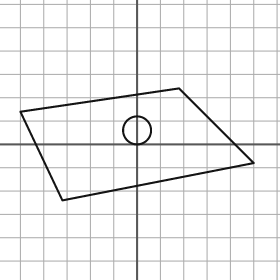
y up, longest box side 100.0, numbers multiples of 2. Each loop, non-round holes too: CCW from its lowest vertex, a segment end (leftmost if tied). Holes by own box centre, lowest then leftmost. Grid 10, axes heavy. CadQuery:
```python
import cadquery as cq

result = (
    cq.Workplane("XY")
    .moveTo(-32.0, -24.0)
    .lineTo(50.0, -8.0)
    .lineTo(18.0, 24.0)
    .lineTo(-50.0, 14.0)
    .close()
    .moveTo(0.0, 6.0)
    .circle(6.0)
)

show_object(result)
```